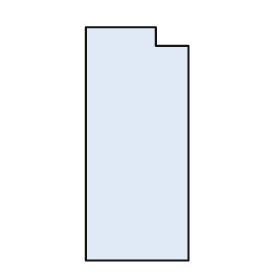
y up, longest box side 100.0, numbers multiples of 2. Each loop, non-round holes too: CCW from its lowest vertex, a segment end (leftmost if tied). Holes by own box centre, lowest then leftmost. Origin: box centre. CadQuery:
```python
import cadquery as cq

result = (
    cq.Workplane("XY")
    .moveTo(-22.0, -50.0)
    .lineTo(22.0, -50.0)
    .lineTo(22.0, 42.0)
    .lineTo(8.0, 42.0)
    .lineTo(8.0, 50.0)
    .lineTo(-22.0, 50.0)
    .close()
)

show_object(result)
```